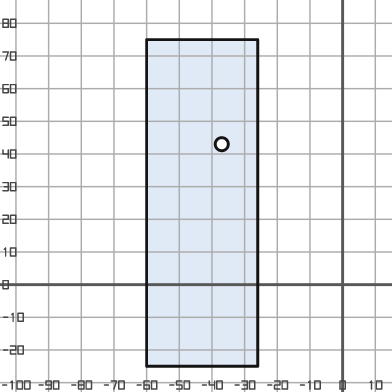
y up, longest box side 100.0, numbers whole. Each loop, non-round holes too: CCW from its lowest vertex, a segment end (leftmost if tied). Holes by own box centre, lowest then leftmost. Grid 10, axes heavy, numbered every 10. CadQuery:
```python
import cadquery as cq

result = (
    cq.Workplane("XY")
    .moveTo(-60.0, -25.0)
    .lineTo(-26.0, -25.0)
    .lineTo(-26.0, 75.0)
    .lineTo(-60.0, 75.0)
    .close()
    .moveTo(-37.0, 43.0)
    .circle(2.0)
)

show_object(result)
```